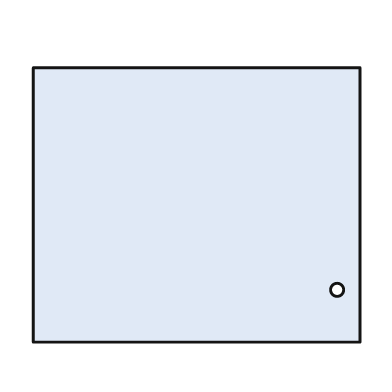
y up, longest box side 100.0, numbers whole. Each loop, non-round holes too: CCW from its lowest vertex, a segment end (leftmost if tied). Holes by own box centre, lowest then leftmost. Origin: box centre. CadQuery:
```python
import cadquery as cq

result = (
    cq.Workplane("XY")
    .moveTo(-50.0, -42.0)
    .lineTo(50.0, -42.0)
    .lineTo(50.0, 42.0)
    .lineTo(-50.0, 42.0)
    .close()
    .moveTo(43.0, -26.0)
    .circle(2.0)
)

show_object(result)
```